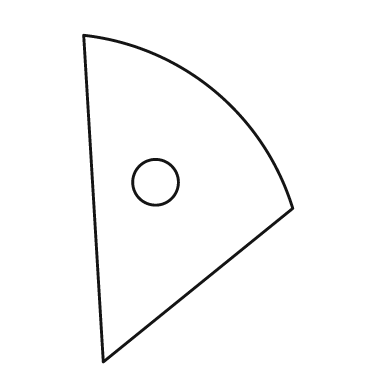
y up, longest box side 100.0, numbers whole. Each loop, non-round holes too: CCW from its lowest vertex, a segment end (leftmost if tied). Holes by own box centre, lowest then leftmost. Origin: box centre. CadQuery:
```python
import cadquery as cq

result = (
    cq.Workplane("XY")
    .moveTo(-26.0, -50.0)
    .lineTo(32.0, -3.0)
    .threePointArc((8.0, 33.0), (-32.0, 50.0))
    .close()
    .moveTo(-10.0, 5.0)
    .circle(7.0)
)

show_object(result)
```